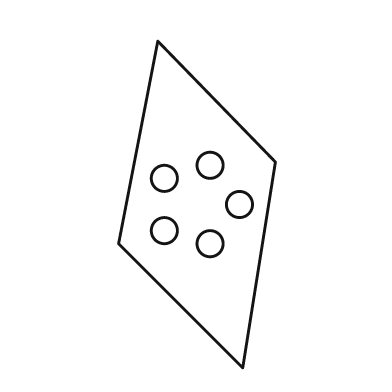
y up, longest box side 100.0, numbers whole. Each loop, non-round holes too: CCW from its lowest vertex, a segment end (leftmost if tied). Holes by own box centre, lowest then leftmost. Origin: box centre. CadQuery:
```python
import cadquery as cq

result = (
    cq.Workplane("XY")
    .moveTo(14.0, -50.0)
    .lineTo(24.0, 13.0)
    .lineTo(-12.0, 50.0)
    .lineTo(-24.0, -12.0)
    .close()
    .moveTo(4.0, -12.0)
    .circle(4.0)
    .moveTo(-10.0, -8.0)
    .circle(4.0)
    .moveTo(13.0, 0.0)
    .circle(4.0)
    .moveTo(-10.0, 8.0)
    .circle(4.0)
    .moveTo(4.0, 12.0)
    .circle(4.0)
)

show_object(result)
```